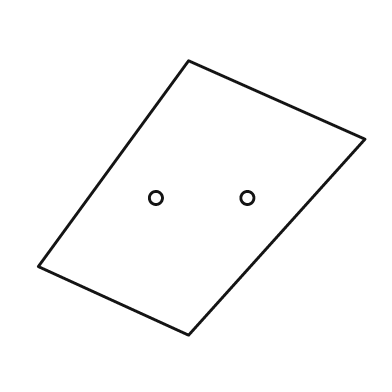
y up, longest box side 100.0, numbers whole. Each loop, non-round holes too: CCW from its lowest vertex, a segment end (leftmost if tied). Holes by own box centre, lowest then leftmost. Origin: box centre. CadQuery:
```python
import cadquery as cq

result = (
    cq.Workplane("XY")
    .moveTo(-4.0, -42.0)
    .lineTo(50.0, 18.0)
    .lineTo(-4.0, 42.0)
    .lineTo(-50.0, -21.0)
    .close()
    .moveTo(-14.0, 0.0)
    .circle(2.0)
    .moveTo(14.0, 0.0)
    .circle(2.0)
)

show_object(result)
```